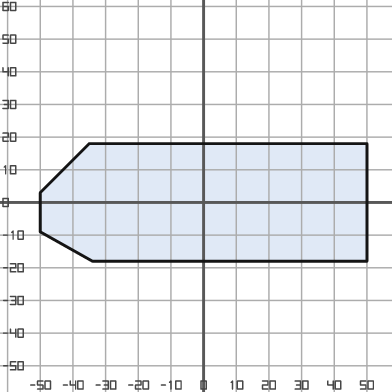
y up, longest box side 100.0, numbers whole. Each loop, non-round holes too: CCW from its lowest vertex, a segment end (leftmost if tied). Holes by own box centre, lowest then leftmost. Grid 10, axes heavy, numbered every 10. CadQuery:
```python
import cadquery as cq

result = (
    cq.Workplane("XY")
    .moveTo(-34.0, -18.0)
    .lineTo(50.0, -18.0)
    .lineTo(50.0, 18.0)
    .lineTo(-35.0, 18.0)
    .lineTo(-50.0, 3.0)
    .lineTo(-50.0, -9.0)
    .close()
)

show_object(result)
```